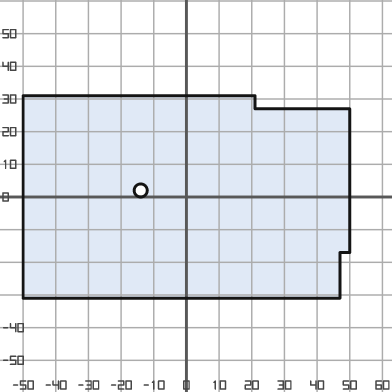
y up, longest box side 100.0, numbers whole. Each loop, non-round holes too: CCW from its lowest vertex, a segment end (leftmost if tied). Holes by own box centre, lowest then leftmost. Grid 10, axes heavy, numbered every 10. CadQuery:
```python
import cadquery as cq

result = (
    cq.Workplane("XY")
    .moveTo(-50.0, -31.0)
    .lineTo(47.0, -31.0)
    .lineTo(47.0, -17.0)
    .lineTo(50.0, -17.0)
    .lineTo(50.0, 27.0)
    .lineTo(21.0, 27.0)
    .lineTo(21.0, 31.0)
    .lineTo(-50.0, 31.0)
    .close()
    .moveTo(-14.0, 2.0)
    .circle(2.0)
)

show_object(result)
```